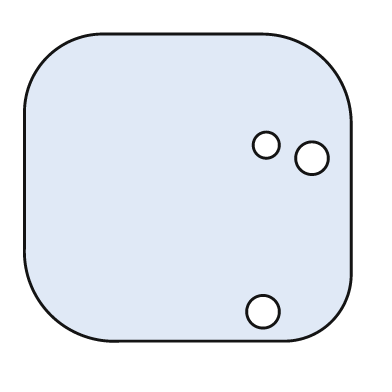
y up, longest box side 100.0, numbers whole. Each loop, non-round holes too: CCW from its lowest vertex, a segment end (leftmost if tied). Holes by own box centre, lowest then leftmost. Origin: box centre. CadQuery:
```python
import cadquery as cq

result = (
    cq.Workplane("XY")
    .moveTo(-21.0, -47.0)
    .lineTo(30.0, -47.0)
    .threePointArc((44.0, -41.0), (50.0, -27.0))
    .lineTo(50.0, 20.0)
    .threePointArc((42.0, 39.0), (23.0, 47.0))
    .lineTo(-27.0, 47.0)
    .threePointArc((-43.0, 40.0), (-50.0, 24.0))
    .lineTo(-50.0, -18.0)
    .threePointArc((-42.0, -39.0), (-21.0, -47.0))
    .close()
    .moveTo(23.0, -38.0)
    .circle(5.0)
    .moveTo(38.0, 9.0)
    .circle(5.0)
    .moveTo(24.0, 13.0)
    .circle(4.0)
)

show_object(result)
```